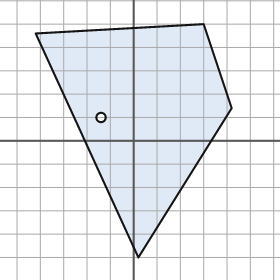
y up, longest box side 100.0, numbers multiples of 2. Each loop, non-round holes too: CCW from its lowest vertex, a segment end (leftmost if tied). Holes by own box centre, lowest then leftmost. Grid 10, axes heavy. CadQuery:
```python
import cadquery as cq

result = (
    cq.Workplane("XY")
    .moveTo(2.0, -50.0)
    .lineTo(42.0, 14.0)
    .lineTo(30.0, 50.0)
    .lineTo(-42.0, 46.0)
    .close()
    .moveTo(-14.0, 10.0)
    .circle(2.0)
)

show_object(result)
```